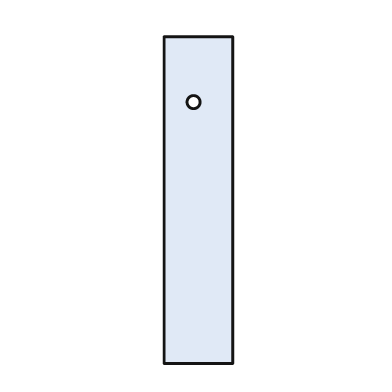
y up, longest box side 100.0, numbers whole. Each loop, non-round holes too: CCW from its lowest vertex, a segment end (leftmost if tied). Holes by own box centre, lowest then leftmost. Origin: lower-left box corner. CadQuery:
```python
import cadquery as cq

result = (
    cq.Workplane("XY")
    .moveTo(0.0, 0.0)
    .lineTo(21.0, 0.0)
    .lineTo(21.0, 100.0)
    .lineTo(0.0, 100.0)
    .close()
    .moveTo(9.0, 80.0)
    .circle(2.0)
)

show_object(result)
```